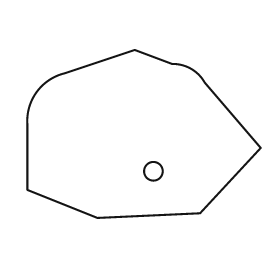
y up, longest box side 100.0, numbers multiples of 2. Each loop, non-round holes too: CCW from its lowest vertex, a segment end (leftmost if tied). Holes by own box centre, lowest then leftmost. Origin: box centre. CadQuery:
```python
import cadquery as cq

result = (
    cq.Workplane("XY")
    .moveTo(-20.0, -36.0)
    .lineTo(24.0, -34.0)
    .lineTo(50.0, -6.0)
    .lineTo(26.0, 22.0)
    .threePointArc((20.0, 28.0), (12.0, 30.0))
    .lineTo(-4.0, 36.0)
    .lineTo(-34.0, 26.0)
    .threePointArc((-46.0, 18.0), (-50.0, 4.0))
    .lineTo(-50.0, -24.0)
    .close()
    .moveTo(4.0, -16.0)
    .circle(4.0)
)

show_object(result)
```